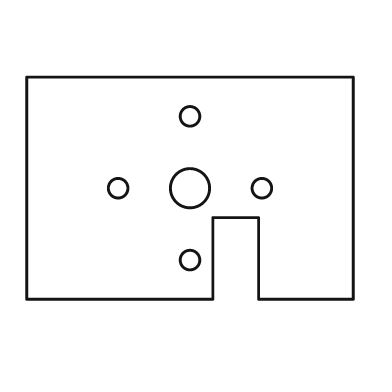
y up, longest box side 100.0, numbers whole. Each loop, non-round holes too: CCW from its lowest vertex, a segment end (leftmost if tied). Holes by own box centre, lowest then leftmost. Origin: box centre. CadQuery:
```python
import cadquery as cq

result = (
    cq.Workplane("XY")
    .moveTo(-50.0, -34.0)
    .lineTo(7.0, -34.0)
    .lineTo(7.0, -9.0)
    .lineTo(21.0, -9.0)
    .lineTo(21.0, -34.0)
    .lineTo(50.0, -34.0)
    .lineTo(50.0, 34.0)
    .lineTo(-50.0, 34.0)
    .close()
    .moveTo(0.0, -22.0)
    .circle(3.0)
    .moveTo(-22.0, 0.0)
    .circle(3.0)
    .moveTo(0.0, 0.0)
    .circle(6.0)
    .moveTo(22.0, 0.0)
    .circle(3.0)
    .moveTo(0.0, 22.0)
    .circle(3.0)
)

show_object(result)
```